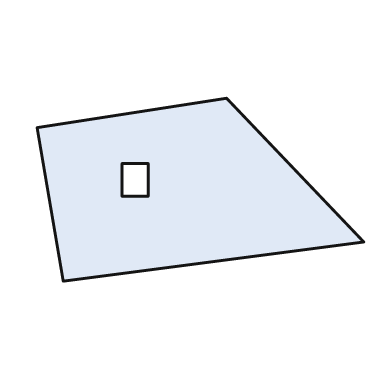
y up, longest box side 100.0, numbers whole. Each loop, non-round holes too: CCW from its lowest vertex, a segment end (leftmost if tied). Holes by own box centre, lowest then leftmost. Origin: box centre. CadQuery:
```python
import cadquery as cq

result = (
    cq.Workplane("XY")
    .moveTo(-42.0, -28.0)
    .lineTo(50.0, -16.0)
    .lineTo(8.0, 28.0)
    .lineTo(-50.0, 19.0)
    .close()
    .moveTo(-24.0, -2.0)
    .lineTo(-16.0, -2.0)
    .lineTo(-16.0, 8.0)
    .lineTo(-24.0, 8.0)
    .close()
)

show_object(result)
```